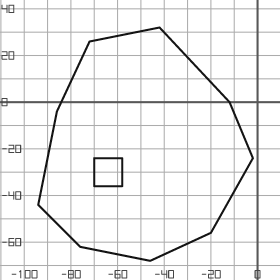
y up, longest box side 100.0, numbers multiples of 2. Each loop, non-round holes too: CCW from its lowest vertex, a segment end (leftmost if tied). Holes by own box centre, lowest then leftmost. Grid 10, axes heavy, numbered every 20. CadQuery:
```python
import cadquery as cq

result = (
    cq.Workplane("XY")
    .moveTo(-46.0, -68.0)
    .lineTo(-20.0, -56.0)
    .lineTo(-2.0, -24.0)
    .lineTo(-12.0, 0.0)
    .lineTo(-42.0, 32.0)
    .lineTo(-72.0, 26.0)
    .lineTo(-86.0, -4.0)
    .lineTo(-94.0, -44.0)
    .lineTo(-76.0, -62.0)
    .close()
    .moveTo(-70.0, -36.0)
    .lineTo(-58.0, -36.0)
    .lineTo(-58.0, -24.0)
    .lineTo(-70.0, -24.0)
    .close()
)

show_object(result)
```